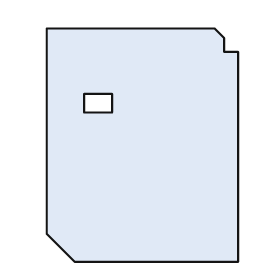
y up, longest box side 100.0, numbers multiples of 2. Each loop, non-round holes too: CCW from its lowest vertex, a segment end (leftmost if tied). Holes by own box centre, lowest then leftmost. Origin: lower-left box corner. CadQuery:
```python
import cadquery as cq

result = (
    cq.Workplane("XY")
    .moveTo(12.0, 0.0)
    .lineTo(82.0, 0.0)
    .lineTo(82.0, 90.0)
    .lineTo(76.0, 90.0)
    .lineTo(76.0, 96.0)
    .lineTo(72.0, 100.0)
    .lineTo(0.0, 100.0)
    .lineTo(0.0, 12.0)
    .close()
    .moveTo(16.0, 64.0)
    .lineTo(28.0, 64.0)
    .lineTo(28.0, 72.0)
    .lineTo(16.0, 72.0)
    .close()
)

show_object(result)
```